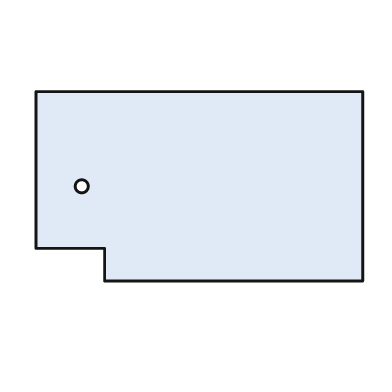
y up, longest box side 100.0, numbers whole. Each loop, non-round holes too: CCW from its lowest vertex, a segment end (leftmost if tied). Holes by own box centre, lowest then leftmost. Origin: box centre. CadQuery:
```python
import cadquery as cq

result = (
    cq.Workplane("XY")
    .moveTo(-29.0, -29.0)
    .lineTo(50.0, -29.0)
    .lineTo(50.0, 29.0)
    .lineTo(-50.0, 29.0)
    .lineTo(-50.0, -19.0)
    .lineTo(-29.0, -19.0)
    .close()
    .moveTo(-36.0, 0.0)
    .circle(2.0)
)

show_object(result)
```